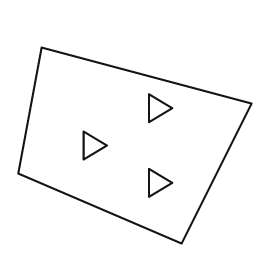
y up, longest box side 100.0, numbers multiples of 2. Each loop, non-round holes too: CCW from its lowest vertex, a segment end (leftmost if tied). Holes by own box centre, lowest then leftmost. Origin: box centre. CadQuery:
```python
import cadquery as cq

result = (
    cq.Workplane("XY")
    .moveTo(20.0, -42.0)
    .lineTo(50.0, 18.0)
    .lineTo(-40.0, 42.0)
    .lineTo(-50.0, -12.0)
    .close()
    .moveTo(6.0, -22.0)
    .lineTo(16.0, -16.0)
    .lineTo(6.0, -10.0)
    .close()
    .moveTo(-22.0, -6.0)
    .lineTo(-12.0, 0.0)
    .lineTo(-22.0, 6.0)
    .close()
    .moveTo(6.0, 10.0)
    .lineTo(16.0, 16.0)
    .lineTo(6.0, 22.0)
    .close()
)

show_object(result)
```